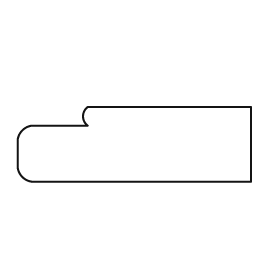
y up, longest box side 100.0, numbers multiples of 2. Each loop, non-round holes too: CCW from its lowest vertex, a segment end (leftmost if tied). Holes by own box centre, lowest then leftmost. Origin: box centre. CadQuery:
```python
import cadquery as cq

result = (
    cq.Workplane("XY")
    .moveTo(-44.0, -16.0)
    .lineTo(50.0, -16.0)
    .lineTo(50.0, 16.0)
    .lineTo(-20.0, 16.0)
    .threePointArc((-22.0, 12.0), (-20.0, 8.0))
    .lineTo(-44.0, 8.0)
    .threePointArc((-48.0, 6.0), (-50.0, 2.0))
    .lineTo(-50.0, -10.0)
    .threePointArc((-48.0, -14.0), (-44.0, -16.0))
    .close()
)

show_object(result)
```